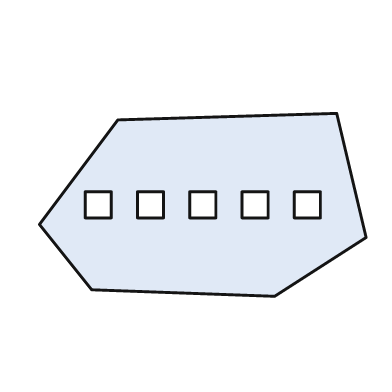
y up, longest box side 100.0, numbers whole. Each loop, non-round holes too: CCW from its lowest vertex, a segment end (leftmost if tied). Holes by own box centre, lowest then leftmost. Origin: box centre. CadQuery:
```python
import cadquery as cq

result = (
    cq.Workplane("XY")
    .moveTo(22.0, -28.0)
    .lineTo(50.0, -10.0)
    .lineTo(41.0, 28.0)
    .lineTo(-26.0, 26.0)
    .lineTo(-50.0, -6.0)
    .lineTo(-34.0, -26.0)
    .close()
    .moveTo(-36.0, -4.0)
    .lineTo(-28.0, -4.0)
    .lineTo(-28.0, 4.0)
    .lineTo(-36.0, 4.0)
    .close()
    .moveTo(-20.0, -4.0)
    .lineTo(-12.0, -4.0)
    .lineTo(-12.0, 4.0)
    .lineTo(-20.0, 4.0)
    .close()
    .moveTo(-4.0, -4.0)
    .lineTo(4.0, -4.0)
    .lineTo(4.0, 4.0)
    .lineTo(-4.0, 4.0)
    .close()
    .moveTo(12.0, -4.0)
    .lineTo(20.0, -4.0)
    .lineTo(20.0, 4.0)
    .lineTo(12.0, 4.0)
    .close()
    .moveTo(28.0, -4.0)
    .lineTo(36.0, -4.0)
    .lineTo(36.0, 4.0)
    .lineTo(28.0, 4.0)
    .close()
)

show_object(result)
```